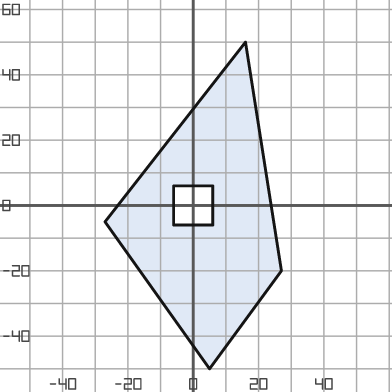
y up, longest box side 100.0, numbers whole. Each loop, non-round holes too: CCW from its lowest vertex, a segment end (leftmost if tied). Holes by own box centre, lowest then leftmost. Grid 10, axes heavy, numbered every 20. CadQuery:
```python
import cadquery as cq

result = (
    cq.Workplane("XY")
    .moveTo(5.0, -50.0)
    .lineTo(27.0, -20.0)
    .lineTo(16.0, 50.0)
    .lineTo(-27.0, -5.0)
    .close()
    .moveTo(-6.0, -6.0)
    .lineTo(6.0, -6.0)
    .lineTo(6.0, 6.0)
    .lineTo(-6.0, 6.0)
    .close()
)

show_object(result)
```